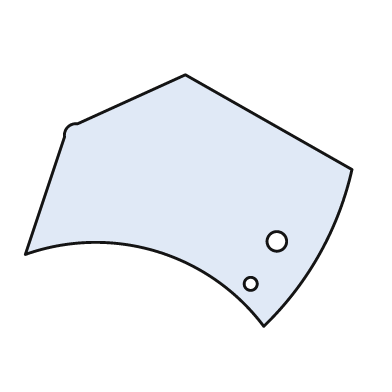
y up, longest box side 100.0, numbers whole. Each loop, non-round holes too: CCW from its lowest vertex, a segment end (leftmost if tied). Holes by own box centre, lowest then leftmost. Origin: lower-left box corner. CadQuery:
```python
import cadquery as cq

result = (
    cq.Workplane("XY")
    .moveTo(73.0, 0.0)
    .threePointArc((90.0, 22.0), (100.0, 48.0))
    .lineTo(49.0, 77.0)
    .lineTo(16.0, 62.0)
    .threePointArc((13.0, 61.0), (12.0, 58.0))
    .lineTo(0.0, 22.0)
    .threePointArc((40.0, 23.0), (73.0, 0.0))
    .close()
    .moveTo(69.0, 13.0)
    .circle(2.0)
    .moveTo(77.0, 26.0)
    .circle(3.0)
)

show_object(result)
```